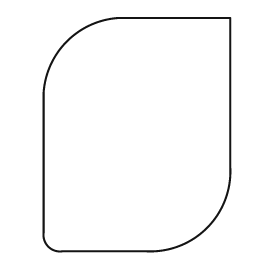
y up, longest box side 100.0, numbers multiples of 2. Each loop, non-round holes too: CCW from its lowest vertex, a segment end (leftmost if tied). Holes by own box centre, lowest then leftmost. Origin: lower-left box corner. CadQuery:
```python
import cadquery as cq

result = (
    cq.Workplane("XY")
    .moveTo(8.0, 0.0)
    .lineTo(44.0, 0.0)
    .threePointArc((70.0, 10.0), (80.0, 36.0))
    .lineTo(80.0, 100.0)
    .lineTo(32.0, 100.0)
    .threePointArc((10.0, 90.0), (0.0, 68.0))
    .lineTo(0.0, 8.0)
    .threePointArc((2.0, 2.0), (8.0, 0.0))
    .close()
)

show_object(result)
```